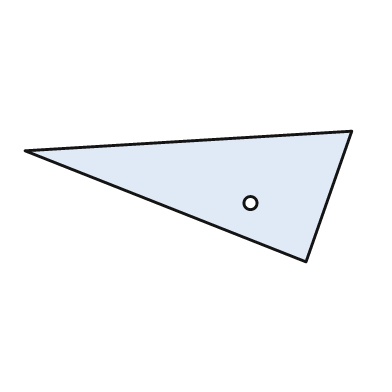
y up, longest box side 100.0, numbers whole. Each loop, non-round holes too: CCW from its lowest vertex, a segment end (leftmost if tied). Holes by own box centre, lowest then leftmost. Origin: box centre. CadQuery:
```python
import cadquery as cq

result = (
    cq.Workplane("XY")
    .moveTo(36.0, -20.0)
    .lineTo(50.0, 20.0)
    .lineTo(-50.0, 14.0)
    .close()
    .moveTo(19.0, -2.0)
    .circle(2.0)
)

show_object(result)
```